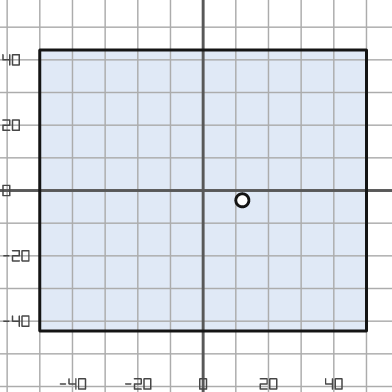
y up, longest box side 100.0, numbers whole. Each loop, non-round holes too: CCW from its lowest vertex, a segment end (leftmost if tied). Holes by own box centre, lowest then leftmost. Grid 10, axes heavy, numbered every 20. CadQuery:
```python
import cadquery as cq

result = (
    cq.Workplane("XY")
    .moveTo(-50.0, -43.0)
    .lineTo(50.0, -43.0)
    .lineTo(50.0, 43.0)
    .lineTo(-50.0, 43.0)
    .close()
    .moveTo(12.0, -3.0)
    .circle(2.0)
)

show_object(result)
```